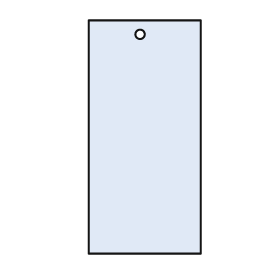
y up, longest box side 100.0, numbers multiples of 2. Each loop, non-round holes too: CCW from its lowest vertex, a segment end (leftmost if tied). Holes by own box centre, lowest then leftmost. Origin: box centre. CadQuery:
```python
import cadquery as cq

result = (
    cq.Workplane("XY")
    .moveTo(-24.0, -50.0)
    .lineTo(24.0, -50.0)
    .lineTo(24.0, 50.0)
    .lineTo(-24.0, 50.0)
    .close()
    .moveTo(-2.0, 44.0)
    .circle(2.0)
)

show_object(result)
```